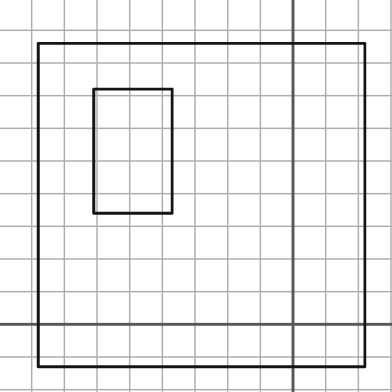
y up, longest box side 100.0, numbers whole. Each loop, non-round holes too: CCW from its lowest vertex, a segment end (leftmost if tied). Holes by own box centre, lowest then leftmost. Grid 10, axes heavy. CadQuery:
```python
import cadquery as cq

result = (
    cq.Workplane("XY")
    .moveTo(-78.0, -13.0)
    .lineTo(22.0, -13.0)
    .lineTo(22.0, 86.0)
    .lineTo(-78.0, 86.0)
    .close()
    .moveTo(-61.0, 34.0)
    .lineTo(-37.0, 34.0)
    .lineTo(-37.0, 72.0)
    .lineTo(-61.0, 72.0)
    .close()
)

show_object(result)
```